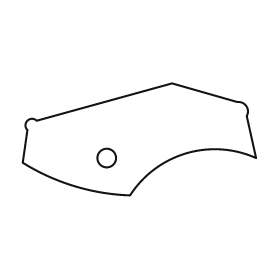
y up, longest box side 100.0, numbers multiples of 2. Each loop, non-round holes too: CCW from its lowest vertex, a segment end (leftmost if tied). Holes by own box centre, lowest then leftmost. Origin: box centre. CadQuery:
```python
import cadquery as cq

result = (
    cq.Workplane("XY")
    .moveTo(-4.0, -24.0)
    .threePointArc((20.0, -6.0), (50.0, -8.0))
    .lineTo(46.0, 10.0)
    .threePointArc((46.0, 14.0), (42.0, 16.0))
    .lineTo(14.0, 24.0)
    .lineTo(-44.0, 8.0)
    .threePointArc((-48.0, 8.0), (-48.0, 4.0))
    .lineTo(-50.0, -10.0)
    .threePointArc((-28.0, -20.0), (-4.0, -24.0))
    .close()
    .moveTo(-14.0, -8.0)
    .circle(4.0)
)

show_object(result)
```